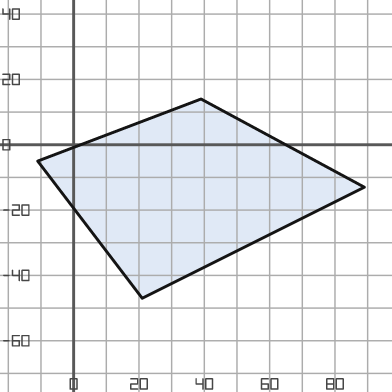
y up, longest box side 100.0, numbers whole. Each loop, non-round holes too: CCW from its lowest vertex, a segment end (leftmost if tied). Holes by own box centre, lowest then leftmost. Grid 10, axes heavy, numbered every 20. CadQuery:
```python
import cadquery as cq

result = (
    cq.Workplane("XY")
    .moveTo(21.0, -47.0)
    .lineTo(89.0, -13.0)
    .lineTo(39.0, 14.0)
    .lineTo(-11.0, -5.0)
    .close()
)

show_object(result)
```